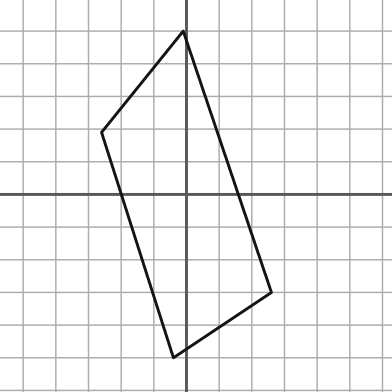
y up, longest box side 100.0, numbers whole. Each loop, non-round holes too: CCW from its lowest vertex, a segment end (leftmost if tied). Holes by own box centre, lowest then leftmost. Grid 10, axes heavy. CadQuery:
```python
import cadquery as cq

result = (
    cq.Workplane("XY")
    .moveTo(-4.0, -50.0)
    .lineTo(26.0, -30.0)
    .lineTo(-1.0, 50.0)
    .lineTo(-26.0, 19.0)
    .close()
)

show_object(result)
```